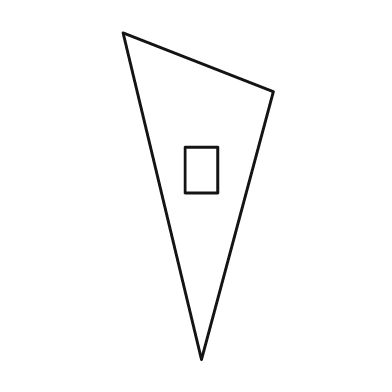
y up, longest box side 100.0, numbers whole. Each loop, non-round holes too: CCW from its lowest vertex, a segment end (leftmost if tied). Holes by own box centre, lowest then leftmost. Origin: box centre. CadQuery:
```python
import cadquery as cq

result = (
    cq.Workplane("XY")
    .moveTo(1.0, -50.0)
    .lineTo(23.0, 32.0)
    .lineTo(-23.0, 50.0)
    .close()
    .moveTo(-4.0, 1.0)
    .lineTo(6.0, 1.0)
    .lineTo(6.0, 15.0)
    .lineTo(-4.0, 15.0)
    .close()
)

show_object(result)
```